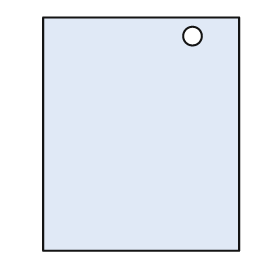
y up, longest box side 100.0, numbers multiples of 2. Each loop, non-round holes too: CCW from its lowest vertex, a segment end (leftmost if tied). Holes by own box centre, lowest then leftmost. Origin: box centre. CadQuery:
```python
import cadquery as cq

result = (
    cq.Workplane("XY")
    .moveTo(-42.0, -50.0)
    .lineTo(42.0, -50.0)
    .lineTo(42.0, 50.0)
    .lineTo(-42.0, 50.0)
    .close()
    .moveTo(22.0, 42.0)
    .circle(4.0)
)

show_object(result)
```